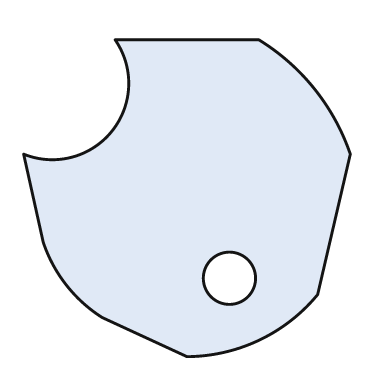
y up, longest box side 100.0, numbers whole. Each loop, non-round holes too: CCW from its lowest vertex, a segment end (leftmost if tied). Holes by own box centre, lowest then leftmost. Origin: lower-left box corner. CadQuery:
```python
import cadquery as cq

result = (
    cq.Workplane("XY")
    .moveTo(50.0, 0.0)
    .threePointArc((72.0, 5.0), (90.0, 19.0))
    .lineTo(100.0, 62.0)
    .threePointArc((89.0, 82.0), (72.0, 97.0))
    .lineTo(28.0, 97.0)
    .threePointArc((27.0, 69.0), (0.0, 62.0))
    .lineTo(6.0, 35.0)
    .threePointArc((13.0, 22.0), (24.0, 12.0))
    .close()
    .moveTo(63.0, 24.0)
    .circle(8.0)
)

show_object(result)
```